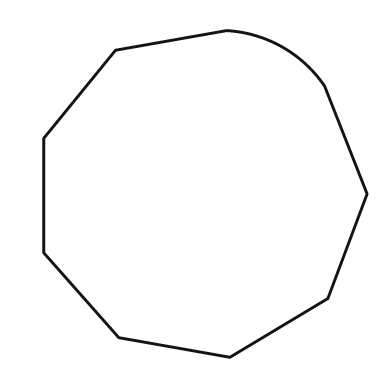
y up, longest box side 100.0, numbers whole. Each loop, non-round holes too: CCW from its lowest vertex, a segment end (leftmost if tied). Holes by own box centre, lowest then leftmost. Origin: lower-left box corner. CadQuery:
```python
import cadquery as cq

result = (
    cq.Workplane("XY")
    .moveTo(57.0, 0.0)
    .lineTo(87.0, 18.0)
    .lineTo(99.0, 50.0)
    .lineTo(86.0, 83.0)
    .threePointArc((73.0, 95.0), (56.0, 100.0))
    .lineTo(22.0, 94.0)
    .lineTo(0.0, 67.0)
    .lineTo(0.0, 32.0)
    .lineTo(23.0, 6.0)
    .close()
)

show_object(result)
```